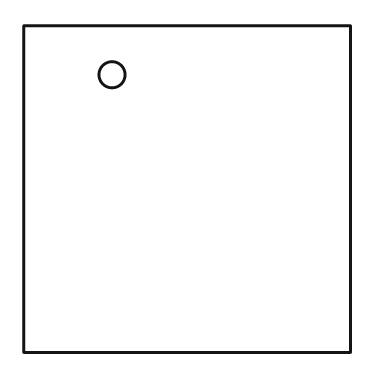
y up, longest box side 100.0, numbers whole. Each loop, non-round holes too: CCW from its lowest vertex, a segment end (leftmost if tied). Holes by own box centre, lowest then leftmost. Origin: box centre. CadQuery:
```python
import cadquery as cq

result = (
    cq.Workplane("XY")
    .moveTo(-50.0, -50.0)
    .lineTo(50.0, -50.0)
    .lineTo(50.0, 50.0)
    .lineTo(-50.0, 50.0)
    .close()
    .moveTo(-23.0, 35.0)
    .circle(4.0)
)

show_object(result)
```